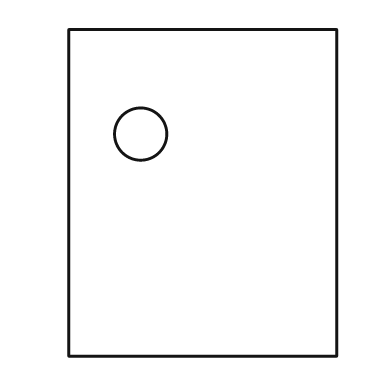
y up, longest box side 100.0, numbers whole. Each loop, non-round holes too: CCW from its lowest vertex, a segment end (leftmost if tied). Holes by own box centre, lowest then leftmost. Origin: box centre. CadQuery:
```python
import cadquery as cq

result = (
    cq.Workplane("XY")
    .moveTo(-41.0, -50.0)
    .lineTo(41.0, -50.0)
    .lineTo(41.0, 50.0)
    .lineTo(-41.0, 50.0)
    .close()
    .moveTo(-19.0, 18.0)
    .circle(8.0)
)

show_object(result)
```